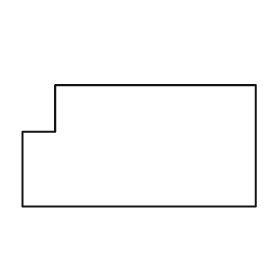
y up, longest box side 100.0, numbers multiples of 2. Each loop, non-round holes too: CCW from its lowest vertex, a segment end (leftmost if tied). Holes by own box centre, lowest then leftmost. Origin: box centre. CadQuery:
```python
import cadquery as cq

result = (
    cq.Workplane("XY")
    .moveTo(-50.0, -26.0)
    .lineTo(50.0, -26.0)
    .lineTo(50.0, 26.0)
    .lineTo(-36.0, 26.0)
    .lineTo(-36.0, 6.0)
    .lineTo(-50.0, 6.0)
    .close()
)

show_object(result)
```